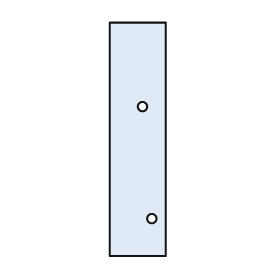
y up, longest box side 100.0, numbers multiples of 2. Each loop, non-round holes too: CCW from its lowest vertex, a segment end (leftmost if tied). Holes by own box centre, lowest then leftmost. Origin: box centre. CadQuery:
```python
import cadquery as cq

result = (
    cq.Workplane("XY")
    .moveTo(-12.0, -50.0)
    .lineTo(12.0, -50.0)
    .lineTo(12.0, 50.0)
    .lineTo(-12.0, 50.0)
    .close()
    .moveTo(6.0, -34.0)
    .circle(2.0)
    .moveTo(2.0, 14.0)
    .circle(2.0)
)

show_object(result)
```